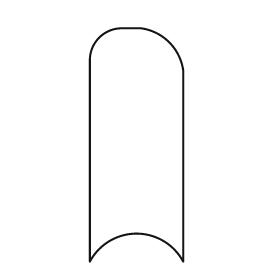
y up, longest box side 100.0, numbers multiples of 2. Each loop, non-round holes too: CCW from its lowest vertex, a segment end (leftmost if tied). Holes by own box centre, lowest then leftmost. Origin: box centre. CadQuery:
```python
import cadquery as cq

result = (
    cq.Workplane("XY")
    .moveTo(-20.0, -50.0)
    .threePointArc((0.0, -38.0), (20.0, -50.0))
    .lineTo(20.0, 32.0)
    .threePointArc((14.0, 44.0), (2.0, 50.0))
    .lineTo(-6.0, 50.0)
    .threePointArc((-16.0, 46.0), (-20.0, 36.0))
    .close()
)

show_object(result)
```